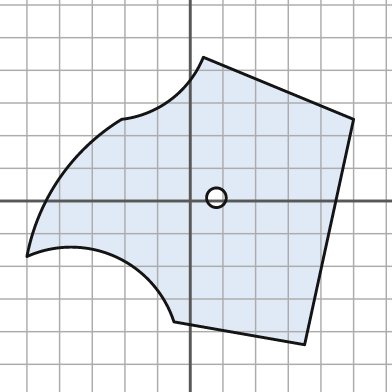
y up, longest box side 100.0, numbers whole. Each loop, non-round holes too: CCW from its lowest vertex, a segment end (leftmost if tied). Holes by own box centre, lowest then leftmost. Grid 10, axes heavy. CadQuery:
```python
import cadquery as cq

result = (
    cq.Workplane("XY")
    .moveTo(35.0, -44.0)
    .lineTo(50.0, 25.0)
    .lineTo(4.0, 44.0)
    .threePointArc((-6.0, 31.0), (-21.0, 25.0))
    .threePointArc((-40.0, 7.0), (-50.0, -17.0))
    .threePointArc((-23.0, -17.0), (-5.0, -37.0))
    .close()
    .moveTo(8.0, 1.0)
    .circle(3.0)
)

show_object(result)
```